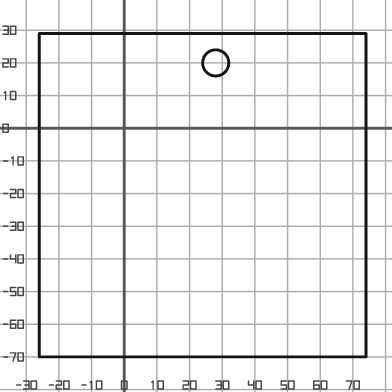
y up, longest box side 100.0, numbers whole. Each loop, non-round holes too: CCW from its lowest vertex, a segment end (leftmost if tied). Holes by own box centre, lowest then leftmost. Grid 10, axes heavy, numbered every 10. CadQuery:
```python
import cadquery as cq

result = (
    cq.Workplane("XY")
    .moveTo(-26.0, -70.0)
    .lineTo(74.0, -70.0)
    .lineTo(74.0, 29.0)
    .lineTo(-26.0, 29.0)
    .close()
    .moveTo(28.0, 20.0)
    .circle(4.0)
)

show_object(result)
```